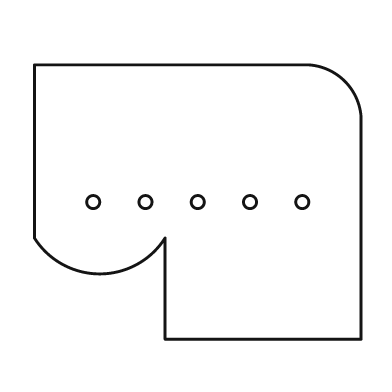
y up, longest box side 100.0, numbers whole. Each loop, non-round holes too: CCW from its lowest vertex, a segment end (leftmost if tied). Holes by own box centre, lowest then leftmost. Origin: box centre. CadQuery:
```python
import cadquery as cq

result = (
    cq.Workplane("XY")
    .moveTo(-10.0, -42.0)
    .lineTo(50.0, -42.0)
    .lineTo(50.0, 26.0)
    .threePointArc((45.0, 37.0), (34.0, 42.0))
    .lineTo(-50.0, 42.0)
    .lineTo(-50.0, -11.0)
    .threePointArc((-30.0, -22.0), (-10.0, -11.0))
    .close()
    .moveTo(-32.0, 0.0)
    .circle(2.0)
    .moveTo(-16.0, 0.0)
    .circle(2.0)
    .moveTo(0.0, 0.0)
    .circle(2.0)
    .moveTo(16.0, 0.0)
    .circle(2.0)
    .moveTo(32.0, 0.0)
    .circle(2.0)
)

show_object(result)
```